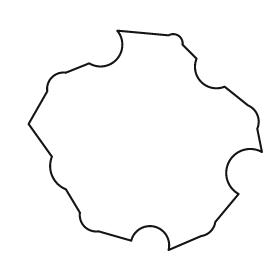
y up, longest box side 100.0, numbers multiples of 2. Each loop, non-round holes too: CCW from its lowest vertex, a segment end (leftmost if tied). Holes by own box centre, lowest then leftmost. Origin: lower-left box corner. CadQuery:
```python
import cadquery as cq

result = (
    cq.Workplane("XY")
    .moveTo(60.0, 0.0)
    .lineTo(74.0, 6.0)
    .threePointArc((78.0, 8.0), (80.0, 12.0))
    .lineTo(90.0, 24.0)
    .threePointArc((86.0, 38.0), (100.0, 42.0))
    .lineTo(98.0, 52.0)
    .threePointArc((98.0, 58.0), (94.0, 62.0))
    .lineTo(84.0, 70.0)
    .threePointArc((74.0, 72.0), (72.0, 82.0))
    .lineTo(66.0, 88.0)
    .threePointArc((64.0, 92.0), (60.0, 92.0))
    .lineTo(38.0, 94.0)
    .threePointArc((38.0, 82.0), (26.0, 80.0))
    .lineTo(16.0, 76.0)
    .threePointArc((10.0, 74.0), (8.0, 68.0))
    .lineTo(0.0, 54.0)
    .lineTo(10.0, 40.0)
    .threePointArc((10.0, 32.0), (16.0, 26.0))
    .lineTo(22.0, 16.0)
    .threePointArc((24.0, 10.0), (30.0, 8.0))
    .lineTo(44.0, 4.0)
    .threePointArc((54.0, 10.0), (60.0, 0.0))
    .close()
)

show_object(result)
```